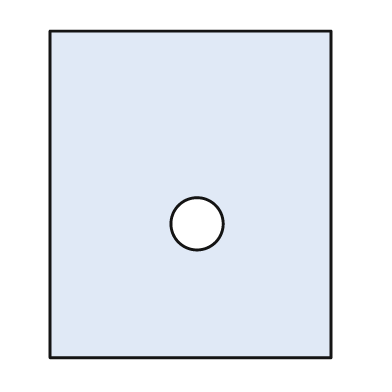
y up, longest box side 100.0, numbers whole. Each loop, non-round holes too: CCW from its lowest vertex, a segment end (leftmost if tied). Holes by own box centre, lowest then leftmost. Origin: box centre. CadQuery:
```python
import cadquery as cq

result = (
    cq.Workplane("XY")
    .moveTo(-43.0, -50.0)
    .lineTo(43.0, -50.0)
    .lineTo(43.0, 50.0)
    .lineTo(-43.0, 50.0)
    .close()
    .moveTo(2.0, -9.0)
    .circle(8.0)
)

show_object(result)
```